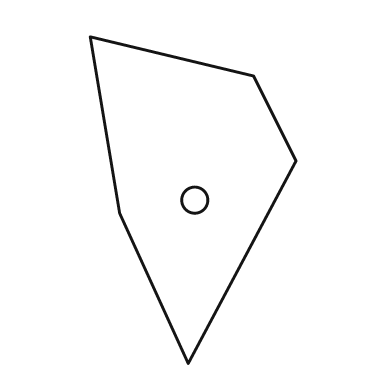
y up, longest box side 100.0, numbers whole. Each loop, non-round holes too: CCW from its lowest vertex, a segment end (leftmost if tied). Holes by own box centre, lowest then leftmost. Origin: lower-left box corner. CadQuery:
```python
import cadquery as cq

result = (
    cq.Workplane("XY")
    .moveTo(30.0, 0.0)
    .lineTo(63.0, 62.0)
    .lineTo(50.0, 88.0)
    .lineTo(0.0, 100.0)
    .lineTo(9.0, 46.0)
    .close()
    .moveTo(32.0, 50.0)
    .circle(4.0)
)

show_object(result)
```